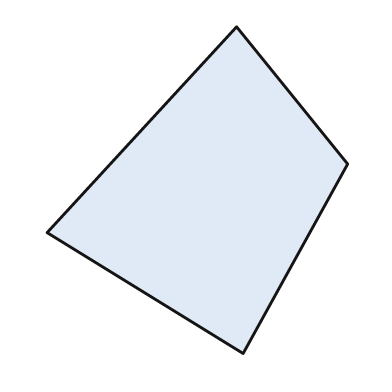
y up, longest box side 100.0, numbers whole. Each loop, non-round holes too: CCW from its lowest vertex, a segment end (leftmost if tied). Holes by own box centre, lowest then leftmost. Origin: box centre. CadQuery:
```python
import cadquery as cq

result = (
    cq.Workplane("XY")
    .moveTo(14.0, -50.0)
    .lineTo(46.0, 8.0)
    .lineTo(12.0, 50.0)
    .lineTo(-46.0, -13.0)
    .close()
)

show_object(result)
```